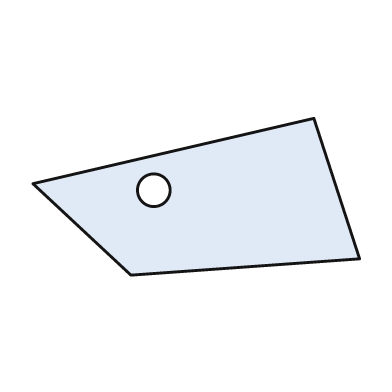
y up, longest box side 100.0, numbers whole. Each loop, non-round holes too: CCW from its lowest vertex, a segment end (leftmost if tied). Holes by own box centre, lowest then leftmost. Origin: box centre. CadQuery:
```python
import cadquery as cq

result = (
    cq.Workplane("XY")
    .moveTo(-20.0, -24.0)
    .lineTo(50.0, -19.0)
    .lineTo(36.0, 24.0)
    .lineTo(-50.0, 4.0)
    .close()
    .moveTo(-13.0, 2.0)
    .circle(5.0)
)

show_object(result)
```